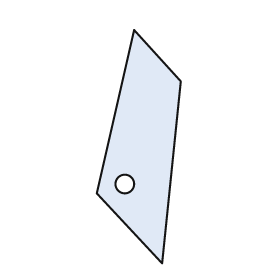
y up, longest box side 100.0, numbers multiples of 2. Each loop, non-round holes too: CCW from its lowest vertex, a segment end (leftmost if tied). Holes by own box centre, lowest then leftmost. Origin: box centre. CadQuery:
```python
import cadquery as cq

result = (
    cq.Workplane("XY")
    .moveTo(10.0, -50.0)
    .lineTo(18.0, 28.0)
    .lineTo(-2.0, 50.0)
    .lineTo(-18.0, -20.0)
    .close()
    .moveTo(-6.0, -16.0)
    .circle(4.0)
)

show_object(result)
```